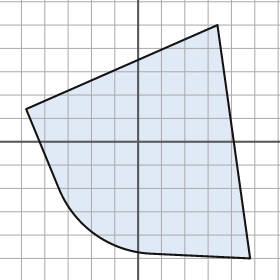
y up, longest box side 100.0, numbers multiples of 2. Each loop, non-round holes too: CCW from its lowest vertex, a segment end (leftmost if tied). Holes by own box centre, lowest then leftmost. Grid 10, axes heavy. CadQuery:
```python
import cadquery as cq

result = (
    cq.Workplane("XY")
    .moveTo(48.0, -50.0)
    .lineTo(34.0, 50.0)
    .lineTo(-48.0, 14.0)
    .lineTo(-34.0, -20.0)
    .threePointArc((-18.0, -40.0), (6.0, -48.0))
    .close()
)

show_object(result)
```